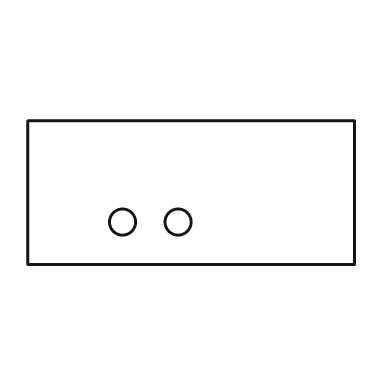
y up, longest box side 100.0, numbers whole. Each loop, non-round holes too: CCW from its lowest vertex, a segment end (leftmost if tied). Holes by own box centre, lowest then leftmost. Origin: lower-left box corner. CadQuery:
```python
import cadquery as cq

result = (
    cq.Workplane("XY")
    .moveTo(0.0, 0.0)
    .lineTo(100.0, 0.0)
    .lineTo(100.0, 44.0)
    .lineTo(0.0, 44.0)
    .close()
    .moveTo(29.0, 13.0)
    .circle(4.0)
    .moveTo(46.0, 13.0)
    .circle(4.0)
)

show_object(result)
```